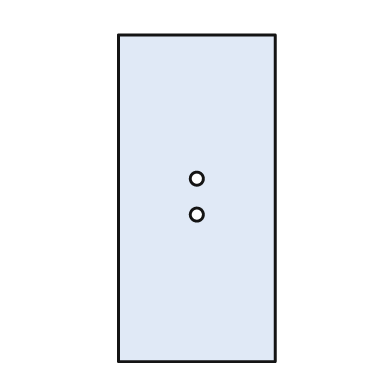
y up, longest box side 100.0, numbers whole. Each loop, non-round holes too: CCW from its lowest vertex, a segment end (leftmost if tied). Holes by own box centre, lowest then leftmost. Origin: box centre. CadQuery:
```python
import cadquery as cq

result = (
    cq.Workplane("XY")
    .moveTo(-24.0, -50.0)
    .lineTo(24.0, -50.0)
    .lineTo(24.0, 50.0)
    .lineTo(-24.0, 50.0)
    .close()
    .moveTo(0.0, -5.0)
    .circle(2.0)
    .moveTo(0.0, 6.0)
    .circle(2.0)
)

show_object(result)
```